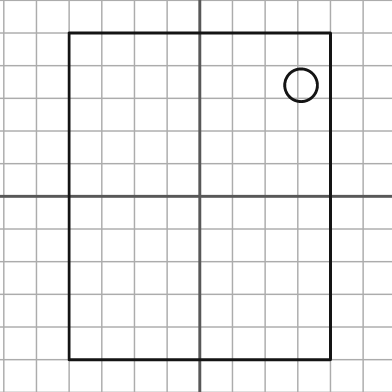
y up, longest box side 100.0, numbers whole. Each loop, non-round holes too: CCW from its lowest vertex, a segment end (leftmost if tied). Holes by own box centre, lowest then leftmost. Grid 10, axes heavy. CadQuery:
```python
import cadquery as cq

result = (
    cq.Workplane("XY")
    .moveTo(-40.0, -50.0)
    .lineTo(40.0, -50.0)
    .lineTo(40.0, 50.0)
    .lineTo(-40.0, 50.0)
    .close()
    .moveTo(31.0, 34.0)
    .circle(5.0)
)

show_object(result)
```